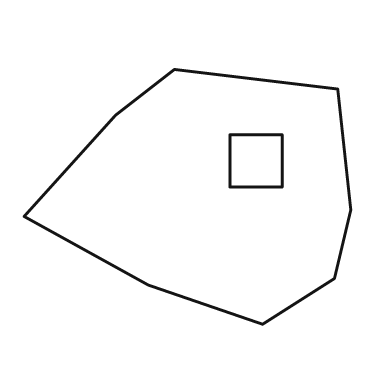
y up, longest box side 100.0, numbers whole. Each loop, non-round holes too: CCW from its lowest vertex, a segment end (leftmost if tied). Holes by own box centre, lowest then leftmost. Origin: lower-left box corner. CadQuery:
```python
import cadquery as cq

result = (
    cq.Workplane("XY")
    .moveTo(73.0, 0.0)
    .lineTo(95.0, 14.0)
    .lineTo(100.0, 35.0)
    .lineTo(96.0, 72.0)
    .lineTo(46.0, 78.0)
    .lineTo(28.0, 64.0)
    .lineTo(0.0, 33.0)
    .lineTo(38.0, 12.0)
    .close()
    .moveTo(63.0, 42.0)
    .lineTo(79.0, 42.0)
    .lineTo(79.0, 58.0)
    .lineTo(63.0, 58.0)
    .close()
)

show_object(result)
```